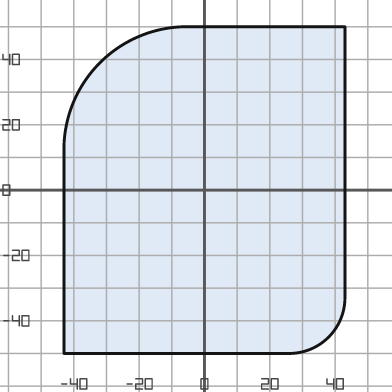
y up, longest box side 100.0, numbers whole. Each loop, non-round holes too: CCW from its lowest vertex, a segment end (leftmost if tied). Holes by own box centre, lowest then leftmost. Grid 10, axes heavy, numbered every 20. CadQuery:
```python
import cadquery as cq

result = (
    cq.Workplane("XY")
    .moveTo(-43.0, -50.0)
    .lineTo(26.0, -50.0)
    .threePointArc((38.0, -45.0), (43.0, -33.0))
    .lineTo(43.0, 50.0)
    .lineTo(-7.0, 50.0)
    .threePointArc((-32.0, 39.0), (-43.0, 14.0))
    .close()
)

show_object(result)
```